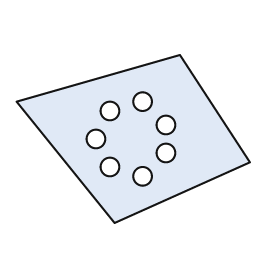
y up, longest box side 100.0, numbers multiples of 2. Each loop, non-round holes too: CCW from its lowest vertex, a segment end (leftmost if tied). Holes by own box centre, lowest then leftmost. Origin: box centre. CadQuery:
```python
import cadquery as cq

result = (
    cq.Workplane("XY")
    .moveTo(-8.0, -36.0)
    .lineTo(50.0, -10.0)
    .lineTo(20.0, 36.0)
    .lineTo(-50.0, 16.0)
    .close()
    .moveTo(4.0, -16.0)
    .circle(4.0)
    .moveTo(-10.0, -12.0)
    .circle(4.0)
    .moveTo(14.0, -6.0)
    .circle(4.0)
    .moveTo(-16.0, 0.0)
    .circle(4.0)
    .moveTo(14.0, 6.0)
    .circle(4.0)
    .moveTo(-10.0, 12.0)
    .circle(4.0)
    .moveTo(4.0, 16.0)
    .circle(4.0)
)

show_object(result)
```